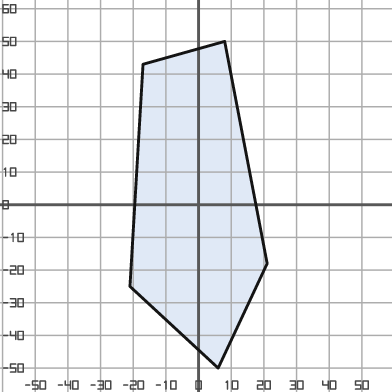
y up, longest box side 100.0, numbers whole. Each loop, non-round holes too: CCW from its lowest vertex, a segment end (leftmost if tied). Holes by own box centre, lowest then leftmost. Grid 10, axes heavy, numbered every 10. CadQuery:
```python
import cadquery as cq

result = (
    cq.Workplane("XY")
    .moveTo(6.0, -50.0)
    .lineTo(21.0, -18.0)
    .lineTo(8.0, 50.0)
    .lineTo(-17.0, 43.0)
    .lineTo(-21.0, -25.0)
    .close()
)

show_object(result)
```